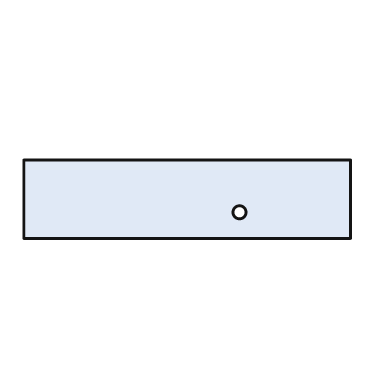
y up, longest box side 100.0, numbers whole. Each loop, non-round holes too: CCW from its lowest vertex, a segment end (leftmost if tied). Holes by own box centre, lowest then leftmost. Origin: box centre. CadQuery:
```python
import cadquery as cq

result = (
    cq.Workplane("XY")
    .moveTo(-50.0, -12.0)
    .lineTo(50.0, -12.0)
    .lineTo(50.0, 12.0)
    .lineTo(-50.0, 12.0)
    .close()
    .moveTo(16.0, -4.0)
    .circle(2.0)
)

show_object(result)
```